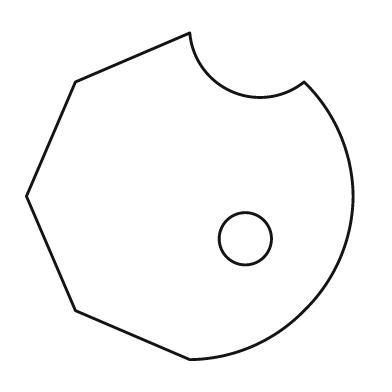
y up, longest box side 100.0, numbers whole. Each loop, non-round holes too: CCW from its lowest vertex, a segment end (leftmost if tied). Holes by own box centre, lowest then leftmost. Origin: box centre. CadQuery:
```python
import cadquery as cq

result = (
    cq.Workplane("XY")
    .moveTo(0.0, -50.0)
    .threePointArc((19.0, -46.0), (35.0, -35.0))
    .threePointArc((46.0, -19.0), (50.0, 0.0))
    .threePointArc((46.0, 19.0), (35.0, 35.0))
    .threePointArc((13.0, 32.0), (0.0, 50.0))
    .lineTo(-35.0, 35.0)
    .lineTo(-50.0, 0.0)
    .lineTo(-35.0, -35.0)
    .close()
    .moveTo(17.0, -13.0)
    .circle(8.0)
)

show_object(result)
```